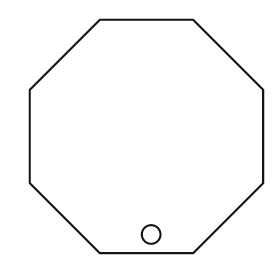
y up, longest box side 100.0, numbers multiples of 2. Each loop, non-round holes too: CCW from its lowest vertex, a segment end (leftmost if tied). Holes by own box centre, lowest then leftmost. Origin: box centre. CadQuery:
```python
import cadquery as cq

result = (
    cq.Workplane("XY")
    .moveTo(-20.0, -50.0)
    .lineTo(20.0, -50.0)
    .lineTo(50.0, -20.0)
    .lineTo(50.0, 20.0)
    .lineTo(20.0, 50.0)
    .lineTo(-20.0, 50.0)
    .lineTo(-50.0, 20.0)
    .lineTo(-50.0, -20.0)
    .close()
    .moveTo(2.0, -42.0)
    .circle(4.0)
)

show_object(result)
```